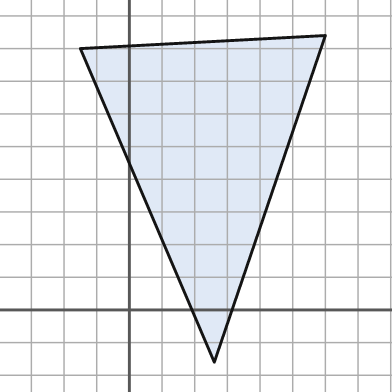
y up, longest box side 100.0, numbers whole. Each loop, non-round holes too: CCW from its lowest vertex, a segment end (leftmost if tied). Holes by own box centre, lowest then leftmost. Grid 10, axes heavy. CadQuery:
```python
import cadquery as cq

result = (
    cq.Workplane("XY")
    .moveTo(26.0, -16.0)
    .lineTo(60.0, 84.0)
    .lineTo(-15.0, 80.0)
    .close()
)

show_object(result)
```